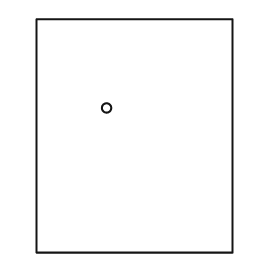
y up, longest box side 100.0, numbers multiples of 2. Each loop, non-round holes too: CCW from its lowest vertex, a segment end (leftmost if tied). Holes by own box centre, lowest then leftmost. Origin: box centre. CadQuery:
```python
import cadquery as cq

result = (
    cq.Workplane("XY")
    .moveTo(-42.0, -50.0)
    .lineTo(42.0, -50.0)
    .lineTo(42.0, 50.0)
    .lineTo(-42.0, 50.0)
    .close()
    .moveTo(-12.0, 12.0)
    .circle(2.0)
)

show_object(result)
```